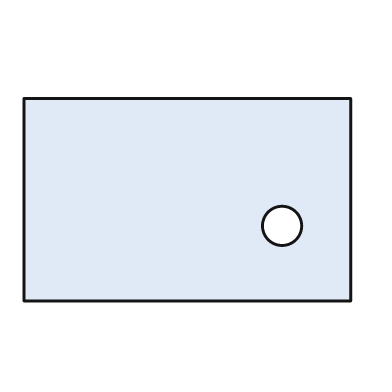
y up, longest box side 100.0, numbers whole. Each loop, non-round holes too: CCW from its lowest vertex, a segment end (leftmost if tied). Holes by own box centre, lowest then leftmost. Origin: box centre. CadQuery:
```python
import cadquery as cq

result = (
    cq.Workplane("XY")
    .moveTo(-50.0, -31.0)
    .lineTo(50.0, -31.0)
    .lineTo(50.0, 31.0)
    .lineTo(-50.0, 31.0)
    .close()
    .moveTo(29.0, -8.0)
    .circle(6.0)
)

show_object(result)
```